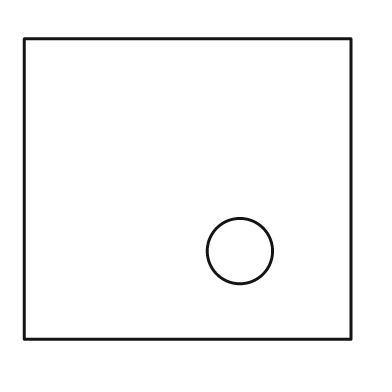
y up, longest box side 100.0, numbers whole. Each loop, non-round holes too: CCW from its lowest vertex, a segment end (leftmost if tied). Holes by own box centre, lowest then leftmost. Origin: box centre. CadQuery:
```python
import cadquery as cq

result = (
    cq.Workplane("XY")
    .moveTo(-50.0, -46.0)
    .lineTo(50.0, -46.0)
    .lineTo(50.0, 46.0)
    .lineTo(-50.0, 46.0)
    .close()
    .moveTo(16.0, -19.0)
    .circle(10.0)
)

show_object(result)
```